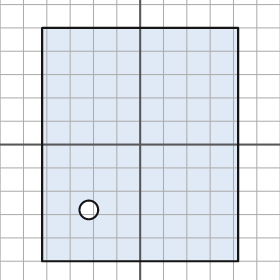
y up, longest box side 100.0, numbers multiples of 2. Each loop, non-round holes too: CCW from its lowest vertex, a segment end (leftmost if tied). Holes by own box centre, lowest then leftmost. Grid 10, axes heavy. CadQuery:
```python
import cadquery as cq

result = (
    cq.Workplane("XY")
    .moveTo(-42.0, -50.0)
    .lineTo(42.0, -50.0)
    .lineTo(42.0, 50.0)
    .lineTo(-42.0, 50.0)
    .close()
    .moveTo(-22.0, -28.0)
    .circle(4.0)
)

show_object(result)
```